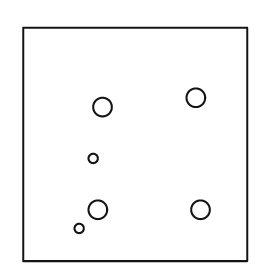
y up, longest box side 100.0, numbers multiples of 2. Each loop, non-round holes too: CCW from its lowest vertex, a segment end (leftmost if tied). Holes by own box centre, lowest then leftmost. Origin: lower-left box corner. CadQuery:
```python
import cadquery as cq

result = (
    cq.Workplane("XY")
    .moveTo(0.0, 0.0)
    .lineTo(96.0, 0.0)
    .lineTo(96.0, 100.0)
    .lineTo(0.0, 100.0)
    .close()
    .moveTo(24.0, 14.0)
    .circle(2.0)
    .moveTo(32.0, 22.0)
    .circle(4.0)
    .moveTo(76.0, 22.0)
    .circle(4.0)
    .moveTo(30.0, 44.0)
    .circle(2.0)
    .moveTo(34.0, 66.0)
    .circle(4.0)
    .moveTo(74.0, 70.0)
    .circle(4.0)
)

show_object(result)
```